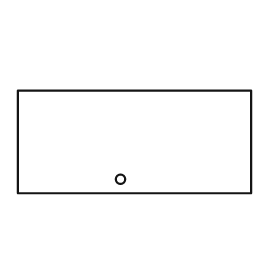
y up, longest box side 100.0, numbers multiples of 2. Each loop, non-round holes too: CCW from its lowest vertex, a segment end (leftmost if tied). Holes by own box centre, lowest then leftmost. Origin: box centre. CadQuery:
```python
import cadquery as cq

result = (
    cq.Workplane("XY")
    .moveTo(-50.0, -22.0)
    .lineTo(50.0, -22.0)
    .lineTo(50.0, 22.0)
    .lineTo(-50.0, 22.0)
    .close()
    .moveTo(-6.0, -16.0)
    .circle(2.0)
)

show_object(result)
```